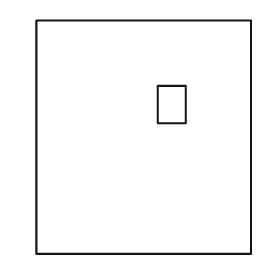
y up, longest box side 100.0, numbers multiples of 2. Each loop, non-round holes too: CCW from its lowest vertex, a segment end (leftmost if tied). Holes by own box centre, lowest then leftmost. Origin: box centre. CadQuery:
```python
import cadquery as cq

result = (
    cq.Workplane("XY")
    .moveTo(-46.0, -50.0)
    .lineTo(46.0, -50.0)
    .lineTo(46.0, 50.0)
    .lineTo(-46.0, 50.0)
    .close()
    .moveTo(6.0, 6.0)
    .lineTo(18.0, 6.0)
    .lineTo(18.0, 22.0)
    .lineTo(6.0, 22.0)
    .close()
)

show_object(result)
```